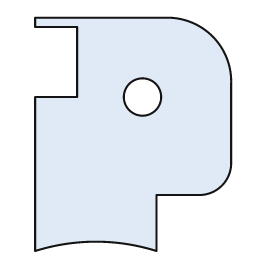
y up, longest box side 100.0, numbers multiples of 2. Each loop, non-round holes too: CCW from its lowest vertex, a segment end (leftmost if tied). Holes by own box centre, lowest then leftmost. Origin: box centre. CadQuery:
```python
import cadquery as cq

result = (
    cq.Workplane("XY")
    .moveTo(-42.0, -50.0)
    .threePointArc((-16.0, -46.0), (10.0, -50.0))
    .lineTo(10.0, -26.0)
    .lineTo(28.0, -26.0)
    .threePointArc((38.0, -22.0), (42.0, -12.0))
    .lineTo(42.0, 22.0)
    .threePointArc((34.0, 42.0), (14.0, 50.0))
    .lineTo(-42.0, 50.0)
    .lineTo(-42.0, 46.0)
    .lineTo(-24.0, 46.0)
    .lineTo(-24.0, 16.0)
    .lineTo(-42.0, 16.0)
    .close()
    .moveTo(4.0, 16.0)
    .circle(8.0)
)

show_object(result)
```